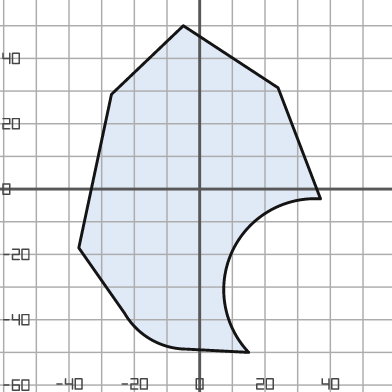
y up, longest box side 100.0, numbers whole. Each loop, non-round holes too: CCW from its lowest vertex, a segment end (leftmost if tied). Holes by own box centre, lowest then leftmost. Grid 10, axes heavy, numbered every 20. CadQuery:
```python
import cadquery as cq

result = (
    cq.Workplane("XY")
    .moveTo(15.0, -50.0)
    .threePointArc((10.0, -19.0), (37.0, -3.0))
    .lineTo(24.0, 31.0)
    .lineTo(-5.0, 50.0)
    .lineTo(-27.0, 29.0)
    .lineTo(-37.0, -18.0)
    .lineTo(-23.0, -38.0)
    .threePointArc((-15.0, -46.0), (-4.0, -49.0))
    .close()
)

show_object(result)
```